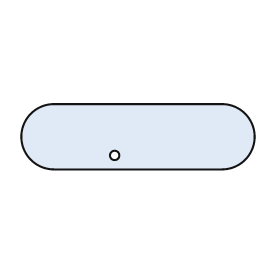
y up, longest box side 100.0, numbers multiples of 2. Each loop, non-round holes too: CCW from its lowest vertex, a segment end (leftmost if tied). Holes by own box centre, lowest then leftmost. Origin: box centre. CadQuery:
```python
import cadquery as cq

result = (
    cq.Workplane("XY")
    .moveTo(-36.0, -14.0)
    .lineTo(36.0, -14.0)
    .threePointArc((50.0, 0.0), (36.0, 14.0))
    .lineTo(-36.0, 14.0)
    .threePointArc((-50.0, 0.0), (-36.0, -14.0))
    .close()
    .moveTo(-10.0, -8.0)
    .circle(2.0)
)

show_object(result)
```